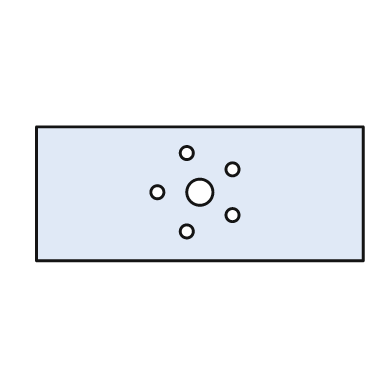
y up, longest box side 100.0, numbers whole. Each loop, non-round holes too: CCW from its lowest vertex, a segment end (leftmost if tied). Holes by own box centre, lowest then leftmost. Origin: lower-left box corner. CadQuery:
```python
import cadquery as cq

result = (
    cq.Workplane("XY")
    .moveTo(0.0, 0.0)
    .lineTo(100.0, 0.0)
    .lineTo(100.0, 41.0)
    .lineTo(0.0, 41.0)
    .close()
    .moveTo(46.0, 9.0)
    .circle(2.0)
    .moveTo(60.0, 14.0)
    .circle(2.0)
    .moveTo(37.0, 21.0)
    .circle(2.0)
    .moveTo(50.0, 21.0)
    .circle(4.0)
    .moveTo(60.0, 28.0)
    .circle(2.0)
    .moveTo(46.0, 33.0)
    .circle(2.0)
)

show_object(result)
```